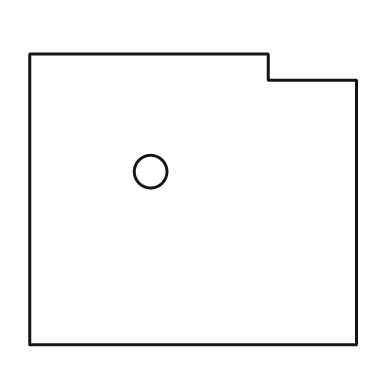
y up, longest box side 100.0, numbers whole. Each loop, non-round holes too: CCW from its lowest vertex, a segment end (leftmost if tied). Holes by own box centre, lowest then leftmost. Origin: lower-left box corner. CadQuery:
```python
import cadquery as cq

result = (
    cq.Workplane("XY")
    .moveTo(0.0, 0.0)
    .lineTo(100.0, 0.0)
    .lineTo(100.0, 81.0)
    .lineTo(73.0, 81.0)
    .lineTo(73.0, 89.0)
    .lineTo(0.0, 89.0)
    .close()
    .moveTo(37.0, 53.0)
    .circle(5.0)
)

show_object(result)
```